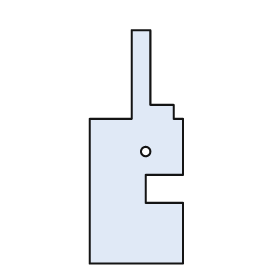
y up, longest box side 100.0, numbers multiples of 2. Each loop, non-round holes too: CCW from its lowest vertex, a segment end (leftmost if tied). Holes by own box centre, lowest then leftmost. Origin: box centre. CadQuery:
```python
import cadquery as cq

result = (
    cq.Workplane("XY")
    .moveTo(-20.0, -50.0)
    .lineTo(20.0, -50.0)
    .lineTo(20.0, -24.0)
    .lineTo(4.0, -24.0)
    .lineTo(4.0, -12.0)
    .lineTo(20.0, -12.0)
    .lineTo(20.0, 12.0)
    .lineTo(16.0, 12.0)
    .lineTo(16.0, 18.0)
    .lineTo(6.0, 18.0)
    .lineTo(6.0, 50.0)
    .lineTo(-2.0, 50.0)
    .lineTo(-2.0, 12.0)
    .lineTo(-20.0, 12.0)
    .close()
    .moveTo(4.0, -2.0)
    .circle(2.0)
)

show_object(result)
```